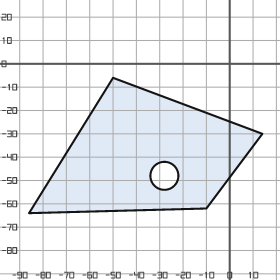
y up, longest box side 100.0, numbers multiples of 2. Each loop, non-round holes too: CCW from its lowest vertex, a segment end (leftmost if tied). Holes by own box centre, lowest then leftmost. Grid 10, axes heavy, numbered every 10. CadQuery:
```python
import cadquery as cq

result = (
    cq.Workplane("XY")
    .moveTo(-86.0, -64.0)
    .lineTo(-10.0, -62.0)
    .lineTo(14.0, -30.0)
    .lineTo(-50.0, -6.0)
    .close()
    .moveTo(-28.0, -48.0)
    .circle(6.0)
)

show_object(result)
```